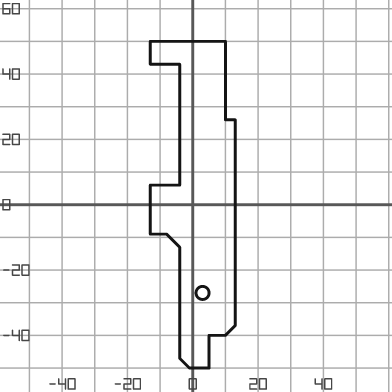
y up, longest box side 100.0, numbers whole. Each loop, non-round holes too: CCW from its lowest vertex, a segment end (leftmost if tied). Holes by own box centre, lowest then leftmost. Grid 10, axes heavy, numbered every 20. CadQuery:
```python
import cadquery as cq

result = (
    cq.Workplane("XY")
    .moveTo(-1.0, -50.0)
    .lineTo(5.0, -50.0)
    .lineTo(5.0, -40.0)
    .lineTo(10.0, -40.0)
    .lineTo(13.0, -37.0)
    .lineTo(13.0, 26.0)
    .lineTo(10.0, 26.0)
    .lineTo(10.0, 50.0)
    .lineTo(-13.0, 50.0)
    .lineTo(-13.0, 43.0)
    .lineTo(-4.0, 43.0)
    .lineTo(-4.0, 6.0)
    .lineTo(-13.0, 6.0)
    .lineTo(-13.0, -9.0)
    .lineTo(-8.0, -9.0)
    .lineTo(-4.0, -13.0)
    .lineTo(-4.0, -47.0)
    .close()
    .moveTo(3.0, -27.0)
    .circle(2.0)
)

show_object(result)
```